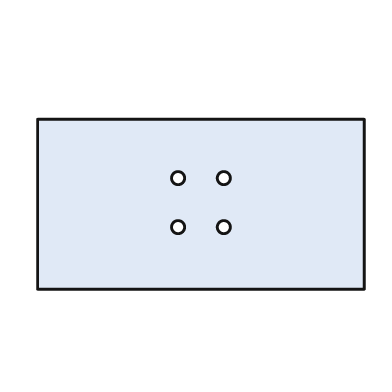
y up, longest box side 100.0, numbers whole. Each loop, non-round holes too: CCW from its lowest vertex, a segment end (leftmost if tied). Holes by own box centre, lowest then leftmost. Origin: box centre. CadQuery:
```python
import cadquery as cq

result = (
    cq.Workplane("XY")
    .moveTo(-50.0, -26.0)
    .lineTo(50.0, -26.0)
    .lineTo(50.0, 26.0)
    .lineTo(-50.0, 26.0)
    .close()
    .moveTo(-7.0, -7.0)
    .circle(2.0)
    .moveTo(7.0, -7.0)
    .circle(2.0)
    .moveTo(-7.0, 8.0)
    .circle(2.0)
    .moveTo(7.0, 8.0)
    .circle(2.0)
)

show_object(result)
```